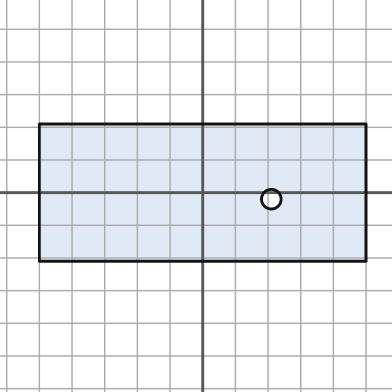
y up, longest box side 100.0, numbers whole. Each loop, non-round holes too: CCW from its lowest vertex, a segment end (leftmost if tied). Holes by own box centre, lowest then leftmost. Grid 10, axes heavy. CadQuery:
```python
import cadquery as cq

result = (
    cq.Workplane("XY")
    .moveTo(-50.0, -21.0)
    .lineTo(50.0, -21.0)
    .lineTo(50.0, 21.0)
    .lineTo(-50.0, 21.0)
    .close()
    .moveTo(21.0, -2.0)
    .circle(3.0)
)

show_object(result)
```